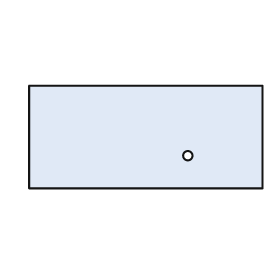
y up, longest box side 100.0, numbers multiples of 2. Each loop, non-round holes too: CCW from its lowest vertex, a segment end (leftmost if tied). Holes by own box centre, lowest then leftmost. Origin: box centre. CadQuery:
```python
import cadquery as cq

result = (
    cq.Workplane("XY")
    .moveTo(-50.0, -22.0)
    .lineTo(50.0, -22.0)
    .lineTo(50.0, 22.0)
    .lineTo(-50.0, 22.0)
    .close()
    .moveTo(18.0, -8.0)
    .circle(2.0)
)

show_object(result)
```